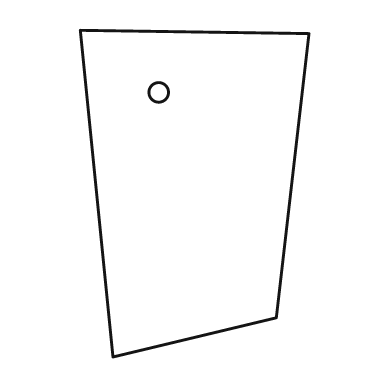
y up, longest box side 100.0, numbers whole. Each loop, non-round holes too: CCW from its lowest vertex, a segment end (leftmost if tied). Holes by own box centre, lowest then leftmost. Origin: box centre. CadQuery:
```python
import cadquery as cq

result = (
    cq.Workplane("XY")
    .moveTo(-25.0, -50.0)
    .lineTo(25.0, -38.0)
    .lineTo(35.0, 49.0)
    .lineTo(-35.0, 50.0)
    .close()
    .moveTo(-11.0, 31.0)
    .circle(3.0)
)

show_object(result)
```